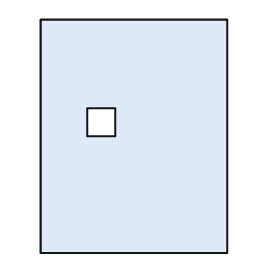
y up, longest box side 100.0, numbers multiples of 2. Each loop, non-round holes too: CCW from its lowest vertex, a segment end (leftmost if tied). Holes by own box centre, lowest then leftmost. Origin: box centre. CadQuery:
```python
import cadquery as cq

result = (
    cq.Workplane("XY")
    .moveTo(-40.0, -50.0)
    .lineTo(40.0, -50.0)
    .lineTo(40.0, 50.0)
    .lineTo(-40.0, 50.0)
    .close()
    .moveTo(-20.0, 0.0)
    .lineTo(-8.0, 0.0)
    .lineTo(-8.0, 12.0)
    .lineTo(-20.0, 12.0)
    .close()
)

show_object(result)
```